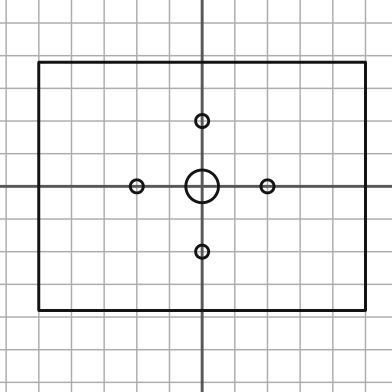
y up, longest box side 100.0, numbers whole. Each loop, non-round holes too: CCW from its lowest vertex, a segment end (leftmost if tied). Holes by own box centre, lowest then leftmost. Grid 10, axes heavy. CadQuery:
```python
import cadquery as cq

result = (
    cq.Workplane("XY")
    .moveTo(-50.0, -38.0)
    .lineTo(50.0, -38.0)
    .lineTo(50.0, 38.0)
    .lineTo(-50.0, 38.0)
    .close()
    .moveTo(0.0, -20.0)
    .circle(2.0)
    .moveTo(-20.0, 0.0)
    .circle(2.0)
    .moveTo(0.0, 0.0)
    .circle(5.0)
    .moveTo(20.0, 0.0)
    .circle(2.0)
    .moveTo(0.0, 20.0)
    .circle(2.0)
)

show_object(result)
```